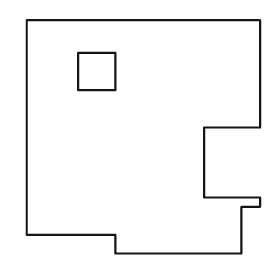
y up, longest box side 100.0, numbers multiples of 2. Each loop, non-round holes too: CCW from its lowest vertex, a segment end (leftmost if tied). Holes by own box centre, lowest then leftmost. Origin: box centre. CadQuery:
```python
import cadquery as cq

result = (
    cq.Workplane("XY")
    .moveTo(-12.0, -50.0)
    .lineTo(42.0, -50.0)
    .lineTo(42.0, -30.0)
    .lineTo(50.0, -30.0)
    .lineTo(50.0, -26.0)
    .lineTo(26.0, -26.0)
    .lineTo(26.0, 4.0)
    .lineTo(50.0, 4.0)
    .lineTo(50.0, 50.0)
    .lineTo(-50.0, 50.0)
    .lineTo(-50.0, -42.0)
    .lineTo(-12.0, -42.0)
    .close()
    .moveTo(-28.0, 20.0)
    .lineTo(-12.0, 20.0)
    .lineTo(-12.0, 36.0)
    .lineTo(-28.0, 36.0)
    .close()
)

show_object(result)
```